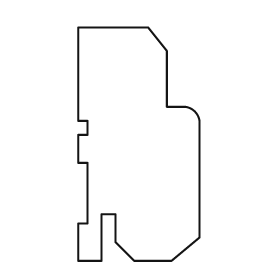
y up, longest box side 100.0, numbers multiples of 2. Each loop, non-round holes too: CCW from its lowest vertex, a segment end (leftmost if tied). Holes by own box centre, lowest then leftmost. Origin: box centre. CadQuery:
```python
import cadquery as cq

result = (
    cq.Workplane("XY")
    .moveTo(-26.0, -50.0)
    .lineTo(-16.0, -50.0)
    .lineTo(-16.0, -30.0)
    .lineTo(-10.0, -30.0)
    .lineTo(-10.0, -42.0)
    .lineTo(-2.0, -50.0)
    .lineTo(14.0, -50.0)
    .lineTo(26.0, -40.0)
    .lineTo(26.0, 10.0)
    .threePointArc((24.0, 14.0), (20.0, 16.0))
    .lineTo(12.0, 16.0)
    .lineTo(12.0, 40.0)
    .lineTo(4.0, 50.0)
    .lineTo(-26.0, 50.0)
    .lineTo(-26.0, 10.0)
    .lineTo(-22.0, 10.0)
    .lineTo(-22.0, 4.0)
    .lineTo(-26.0, 4.0)
    .lineTo(-26.0, -8.0)
    .lineTo(-22.0, -8.0)
    .lineTo(-22.0, -34.0)
    .lineTo(-26.0, -34.0)
    .close()
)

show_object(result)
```